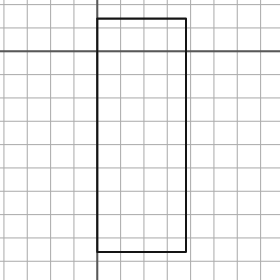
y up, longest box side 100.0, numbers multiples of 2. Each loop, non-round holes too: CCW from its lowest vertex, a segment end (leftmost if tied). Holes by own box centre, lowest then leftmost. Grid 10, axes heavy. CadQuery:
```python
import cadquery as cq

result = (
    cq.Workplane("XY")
    .moveTo(0.0, -86.0)
    .lineTo(38.0, -86.0)
    .lineTo(38.0, 14.0)
    .lineTo(0.0, 14.0)
    .close()
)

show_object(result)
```